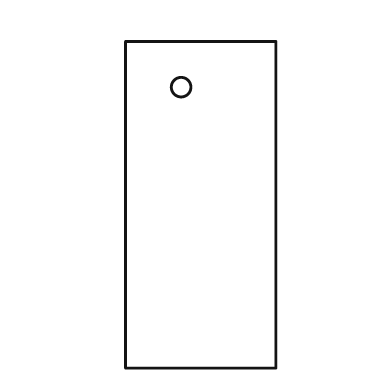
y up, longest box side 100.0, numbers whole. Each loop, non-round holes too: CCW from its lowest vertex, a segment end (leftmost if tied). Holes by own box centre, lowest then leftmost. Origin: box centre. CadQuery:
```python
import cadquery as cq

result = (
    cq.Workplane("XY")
    .moveTo(-23.0, -50.0)
    .lineTo(23.0, -50.0)
    .lineTo(23.0, 50.0)
    .lineTo(-23.0, 50.0)
    .close()
    .moveTo(-6.0, 36.0)
    .circle(3.0)
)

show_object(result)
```